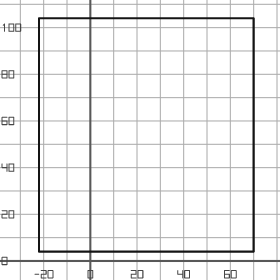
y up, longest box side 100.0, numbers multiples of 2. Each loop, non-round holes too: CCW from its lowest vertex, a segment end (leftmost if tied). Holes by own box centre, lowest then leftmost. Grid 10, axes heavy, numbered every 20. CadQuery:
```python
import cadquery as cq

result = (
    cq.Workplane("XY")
    .moveTo(-22.0, 4.0)
    .lineTo(70.0, 4.0)
    .lineTo(70.0, 104.0)
    .lineTo(-22.0, 104.0)
    .close()
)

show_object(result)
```